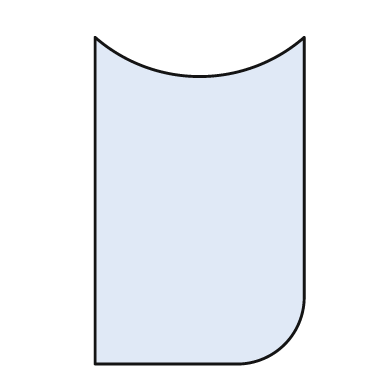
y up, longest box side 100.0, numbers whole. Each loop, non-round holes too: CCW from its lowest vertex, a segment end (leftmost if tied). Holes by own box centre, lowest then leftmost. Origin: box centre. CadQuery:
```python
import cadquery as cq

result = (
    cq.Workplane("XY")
    .moveTo(-32.0, -50.0)
    .lineTo(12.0, -50.0)
    .threePointArc((26.0, -44.0), (32.0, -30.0))
    .lineTo(32.0, 50.0)
    .threePointArc((0.0, 38.0), (-32.0, 50.0))
    .close()
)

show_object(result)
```